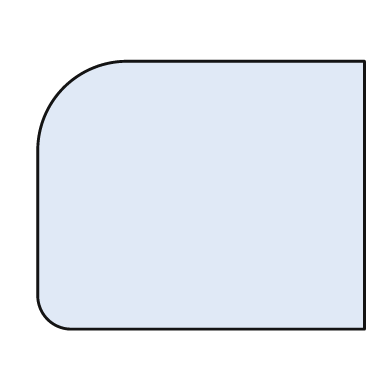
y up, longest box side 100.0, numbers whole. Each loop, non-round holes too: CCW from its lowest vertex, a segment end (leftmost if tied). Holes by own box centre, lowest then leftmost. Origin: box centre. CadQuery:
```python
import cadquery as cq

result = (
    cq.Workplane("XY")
    .moveTo(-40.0, -41.0)
    .lineTo(50.0, -41.0)
    .lineTo(50.0, 41.0)
    .lineTo(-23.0, 41.0)
    .threePointArc((-42.0, 33.0), (-50.0, 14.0))
    .lineTo(-50.0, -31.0)
    .threePointArc((-47.0, -38.0), (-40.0, -41.0))
    .close()
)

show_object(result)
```